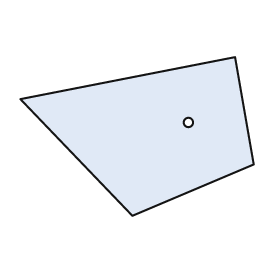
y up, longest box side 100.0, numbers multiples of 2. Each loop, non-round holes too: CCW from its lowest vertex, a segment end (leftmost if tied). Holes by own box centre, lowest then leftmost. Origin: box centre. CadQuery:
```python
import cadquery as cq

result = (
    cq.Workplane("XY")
    .moveTo(-2.0, -34.0)
    .lineTo(50.0, -12.0)
    .lineTo(42.0, 34.0)
    .lineTo(-50.0, 16.0)
    .close()
    .moveTo(22.0, 6.0)
    .circle(2.0)
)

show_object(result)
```